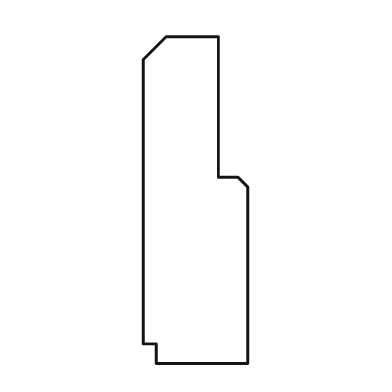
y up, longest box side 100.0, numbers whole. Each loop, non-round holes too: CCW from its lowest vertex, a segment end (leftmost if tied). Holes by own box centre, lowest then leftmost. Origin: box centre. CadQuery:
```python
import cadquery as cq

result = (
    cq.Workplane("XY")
    .moveTo(-12.0, -50.0)
    .lineTo(16.0, -50.0)
    .lineTo(16.0, 4.0)
    .lineTo(13.0, 7.0)
    .lineTo(7.0, 7.0)
    .lineTo(7.0, 50.0)
    .lineTo(-9.0, 50.0)
    .lineTo(-16.0, 43.0)
    .lineTo(-16.0, -44.0)
    .lineTo(-12.0, -44.0)
    .close()
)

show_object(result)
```